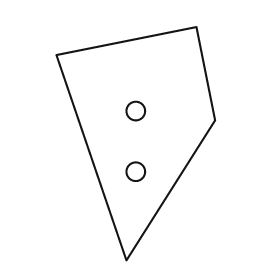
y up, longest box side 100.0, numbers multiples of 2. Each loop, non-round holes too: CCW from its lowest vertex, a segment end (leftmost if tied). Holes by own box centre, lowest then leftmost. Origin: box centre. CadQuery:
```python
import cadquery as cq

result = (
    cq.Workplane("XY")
    .moveTo(-4.0, -50.0)
    .lineTo(34.0, 10.0)
    .lineTo(26.0, 50.0)
    .lineTo(-34.0, 38.0)
    .close()
    .moveTo(0.0, -12.0)
    .circle(4.0)
    .moveTo(0.0, 14.0)
    .circle(4.0)
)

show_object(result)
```